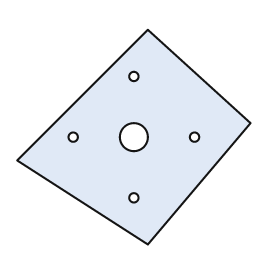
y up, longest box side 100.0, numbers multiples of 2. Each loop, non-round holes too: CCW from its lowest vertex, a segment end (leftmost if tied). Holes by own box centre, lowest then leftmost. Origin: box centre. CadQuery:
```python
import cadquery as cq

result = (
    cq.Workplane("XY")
    .moveTo(6.0, -46.0)
    .lineTo(50.0, 6.0)
    .lineTo(6.0, 46.0)
    .lineTo(-50.0, -10.0)
    .close()
    .moveTo(0.0, -26.0)
    .circle(2.0)
    .moveTo(-26.0, 0.0)
    .circle(2.0)
    .moveTo(0.0, 0.0)
    .circle(6.0)
    .moveTo(26.0, 0.0)
    .circle(2.0)
    .moveTo(0.0, 26.0)
    .circle(2.0)
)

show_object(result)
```